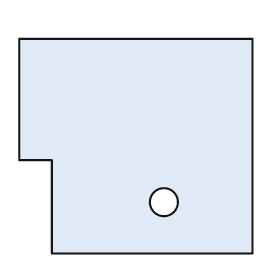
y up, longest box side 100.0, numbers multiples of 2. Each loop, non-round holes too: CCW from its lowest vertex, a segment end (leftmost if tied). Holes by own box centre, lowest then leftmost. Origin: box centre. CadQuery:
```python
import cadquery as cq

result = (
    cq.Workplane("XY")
    .moveTo(-36.0, -46.0)
    .lineTo(50.0, -46.0)
    .lineTo(50.0, 46.0)
    .lineTo(-50.0, 46.0)
    .lineTo(-50.0, -6.0)
    .lineTo(-36.0, -6.0)
    .close()
    .moveTo(12.0, -24.0)
    .circle(6.0)
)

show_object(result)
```